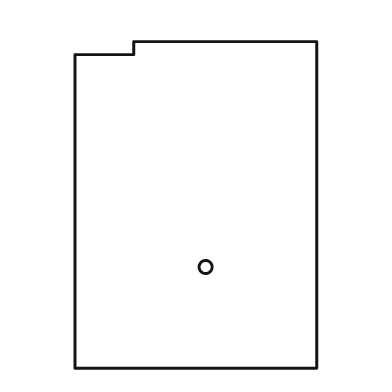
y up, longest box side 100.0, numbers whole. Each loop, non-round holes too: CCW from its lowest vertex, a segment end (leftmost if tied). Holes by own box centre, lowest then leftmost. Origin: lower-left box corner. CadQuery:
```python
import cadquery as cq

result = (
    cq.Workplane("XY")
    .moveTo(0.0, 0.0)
    .lineTo(74.0, 0.0)
    .lineTo(74.0, 100.0)
    .lineTo(18.0, 100.0)
    .lineTo(18.0, 96.0)
    .lineTo(0.0, 96.0)
    .close()
    .moveTo(40.0, 31.0)
    .circle(2.0)
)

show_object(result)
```